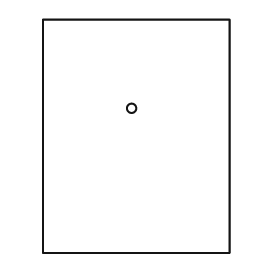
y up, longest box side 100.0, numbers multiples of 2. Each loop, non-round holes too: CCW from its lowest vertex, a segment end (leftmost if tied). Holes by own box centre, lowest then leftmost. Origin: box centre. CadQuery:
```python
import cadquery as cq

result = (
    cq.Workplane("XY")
    .moveTo(-40.0, -50.0)
    .lineTo(40.0, -50.0)
    .lineTo(40.0, 50.0)
    .lineTo(-40.0, 50.0)
    .close()
    .moveTo(-2.0, 12.0)
    .circle(2.0)
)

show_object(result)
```